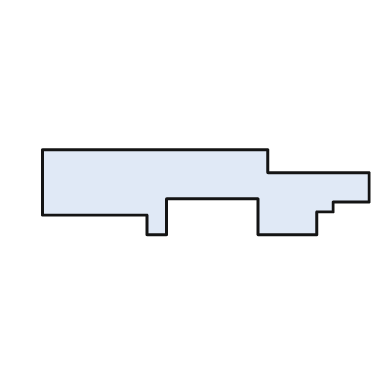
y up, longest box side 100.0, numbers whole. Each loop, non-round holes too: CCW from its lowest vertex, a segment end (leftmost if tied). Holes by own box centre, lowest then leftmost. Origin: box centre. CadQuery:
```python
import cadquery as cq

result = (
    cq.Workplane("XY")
    .moveTo(-18.0, -13.0)
    .lineTo(-12.0, -13.0)
    .lineTo(-12.0, -2.0)
    .lineTo(16.0, -2.0)
    .lineTo(16.0, -13.0)
    .lineTo(34.0, -13.0)
    .lineTo(34.0, -6.0)
    .lineTo(39.0, -6.0)
    .lineTo(39.0, -3.0)
    .lineTo(50.0, -3.0)
    .lineTo(50.0, 6.0)
    .lineTo(19.0, 6.0)
    .lineTo(19.0, 13.0)
    .lineTo(-50.0, 13.0)
    .lineTo(-50.0, -7.0)
    .lineTo(-18.0, -7.0)
    .close()
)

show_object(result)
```